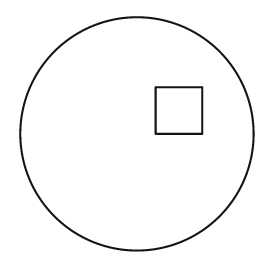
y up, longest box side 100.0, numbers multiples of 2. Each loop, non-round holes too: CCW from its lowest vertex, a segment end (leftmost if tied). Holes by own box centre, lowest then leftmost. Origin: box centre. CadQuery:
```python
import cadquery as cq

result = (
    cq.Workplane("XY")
    .moveTo(0.0, 0.0)
    .circle(50.0)
    .moveTo(8.0, 0.0)
    .lineTo(28.0, 0.0)
    .lineTo(28.0, 20.0)
    .lineTo(8.0, 20.0)
    .close()
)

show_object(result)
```